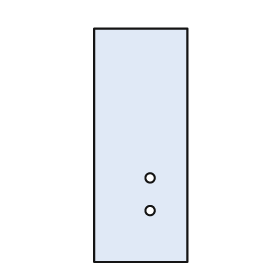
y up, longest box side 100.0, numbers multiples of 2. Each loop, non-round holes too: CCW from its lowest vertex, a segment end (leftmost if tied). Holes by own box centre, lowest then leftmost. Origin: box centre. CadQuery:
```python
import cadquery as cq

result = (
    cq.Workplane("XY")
    .moveTo(-20.0, -50.0)
    .lineTo(20.0, -50.0)
    .lineTo(20.0, 50.0)
    .lineTo(-20.0, 50.0)
    .close()
    .moveTo(4.0, -28.0)
    .circle(2.0)
    .moveTo(4.0, -14.0)
    .circle(2.0)
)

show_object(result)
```